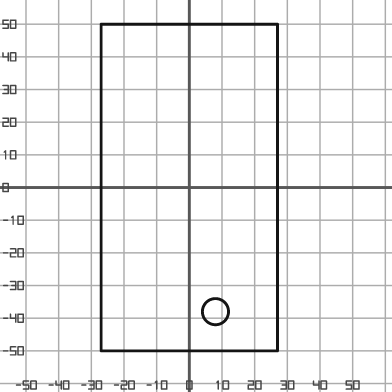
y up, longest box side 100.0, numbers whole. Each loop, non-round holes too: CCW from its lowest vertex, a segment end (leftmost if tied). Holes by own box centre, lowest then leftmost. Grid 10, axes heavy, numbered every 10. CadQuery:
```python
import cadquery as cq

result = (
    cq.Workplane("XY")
    .moveTo(-27.0, -50.0)
    .lineTo(27.0, -50.0)
    .lineTo(27.0, 50.0)
    .lineTo(-27.0, 50.0)
    .close()
    .moveTo(8.0, -38.0)
    .circle(4.0)
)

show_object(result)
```